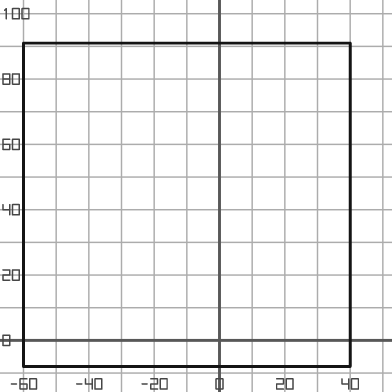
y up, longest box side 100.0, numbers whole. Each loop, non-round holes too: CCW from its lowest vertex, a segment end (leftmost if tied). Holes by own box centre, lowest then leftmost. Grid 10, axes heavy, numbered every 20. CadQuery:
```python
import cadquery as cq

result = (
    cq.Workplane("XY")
    .moveTo(-60.0, -8.0)
    .lineTo(40.0, -8.0)
    .lineTo(40.0, 91.0)
    .lineTo(-60.0, 91.0)
    .close()
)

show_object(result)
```